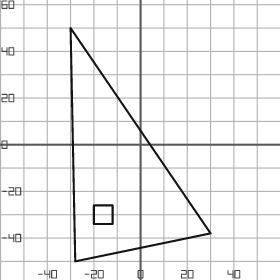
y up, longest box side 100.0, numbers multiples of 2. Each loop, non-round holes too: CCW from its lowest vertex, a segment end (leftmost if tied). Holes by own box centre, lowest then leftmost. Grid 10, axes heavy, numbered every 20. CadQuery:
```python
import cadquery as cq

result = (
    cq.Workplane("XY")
    .moveTo(-28.0, -50.0)
    .lineTo(30.0, -38.0)
    .lineTo(-30.0, 50.0)
    .close()
    .moveTo(-20.0, -34.0)
    .lineTo(-12.0, -34.0)
    .lineTo(-12.0, -26.0)
    .lineTo(-20.0, -26.0)
    .close()
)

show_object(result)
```